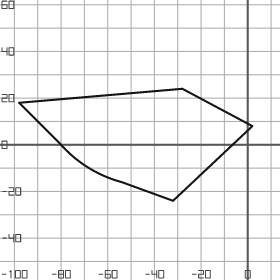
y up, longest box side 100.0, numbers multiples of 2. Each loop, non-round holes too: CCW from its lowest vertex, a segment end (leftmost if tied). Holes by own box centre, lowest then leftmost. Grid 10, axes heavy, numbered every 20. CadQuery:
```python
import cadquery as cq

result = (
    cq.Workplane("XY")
    .moveTo(-32.0, -24.0)
    .lineTo(2.0, 8.0)
    .lineTo(-28.0, 24.0)
    .lineTo(-98.0, 18.0)
    .lineTo(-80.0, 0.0)
    .threePointArc((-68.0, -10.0), (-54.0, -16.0))
    .close()
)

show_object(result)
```